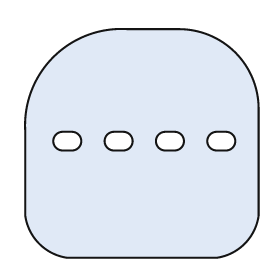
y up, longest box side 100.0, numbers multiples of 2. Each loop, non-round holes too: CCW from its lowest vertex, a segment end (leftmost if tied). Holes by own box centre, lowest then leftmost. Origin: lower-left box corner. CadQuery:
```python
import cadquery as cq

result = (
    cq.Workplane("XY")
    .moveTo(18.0, 0.0)
    .lineTo(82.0, 0.0)
    .threePointArc((94.0, 6.0), (100.0, 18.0))
    .lineTo(100.0, 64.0)
    .threePointArc((90.0, 88.0), (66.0, 98.0))
    .lineTo(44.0, 98.0)
    .threePointArc((12.0, 86.0), (0.0, 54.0))
    .lineTo(0.0, 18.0)
    .threePointArc((6.0, 6.0), (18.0, 0.0))
    .close()
    .moveTo(16.0, 46.0)
    .lineTo(20.0, 46.0)
    .threePointArc((24.0, 50.0), (20.0, 54.0))
    .lineTo(16.0, 54.0)
    .threePointArc((12.0, 50.0), (16.0, 46.0))
    .close()
    .moveTo(38.0, 46.0)
    .lineTo(42.0, 46.0)
    .threePointArc((46.0, 50.0), (42.0, 54.0))
    .lineTo(38.0, 54.0)
    .threePointArc((34.0, 50.0), (38.0, 46.0))
    .close()
    .moveTo(60.0, 46.0)
    .lineTo(64.0, 46.0)
    .threePointArc((68.0, 50.0), (64.0, 54.0))
    .lineTo(60.0, 54.0)
    .threePointArc((56.0, 50.0), (60.0, 46.0))
    .close()
    .moveTo(82.0, 46.0)
    .lineTo(86.0, 46.0)
    .threePointArc((90.0, 50.0), (86.0, 54.0))
    .lineTo(82.0, 54.0)
    .threePointArc((78.0, 50.0), (82.0, 46.0))
    .close()
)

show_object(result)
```